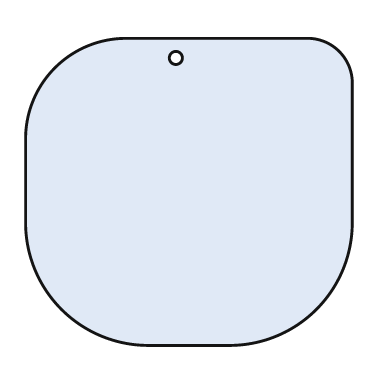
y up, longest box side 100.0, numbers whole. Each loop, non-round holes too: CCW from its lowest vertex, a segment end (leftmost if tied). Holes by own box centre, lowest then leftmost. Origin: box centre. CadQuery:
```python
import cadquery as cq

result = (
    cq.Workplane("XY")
    .moveTo(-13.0, -47.0)
    .lineTo(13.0, -47.0)
    .threePointArc((39.0, -36.0), (50.0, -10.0))
    .lineTo(50.0, 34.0)
    .threePointArc((46.0, 43.0), (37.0, 47.0))
    .lineTo(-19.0, 47.0)
    .threePointArc((-41.0, 38.0), (-50.0, 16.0))
    .lineTo(-50.0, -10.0)
    .threePointArc((-39.0, -36.0), (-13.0, -47.0))
    .close()
    .moveTo(-4.0, 41.0)
    .circle(2.0)
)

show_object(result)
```